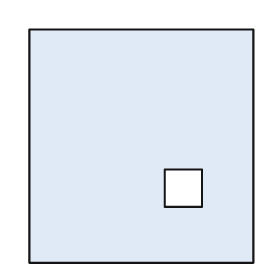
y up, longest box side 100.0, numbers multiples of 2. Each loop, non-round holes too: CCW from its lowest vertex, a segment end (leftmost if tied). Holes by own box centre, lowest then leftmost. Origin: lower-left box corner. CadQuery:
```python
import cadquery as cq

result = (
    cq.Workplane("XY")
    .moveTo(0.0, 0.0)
    .lineTo(96.0, 0.0)
    .lineTo(96.0, 100.0)
    .lineTo(0.0, 100.0)
    .close()
    .moveTo(58.0, 24.0)
    .lineTo(74.0, 24.0)
    .lineTo(74.0, 40.0)
    .lineTo(58.0, 40.0)
    .close()
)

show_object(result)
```